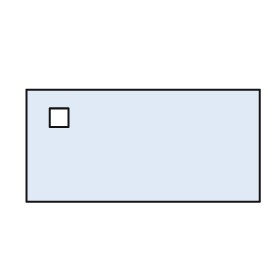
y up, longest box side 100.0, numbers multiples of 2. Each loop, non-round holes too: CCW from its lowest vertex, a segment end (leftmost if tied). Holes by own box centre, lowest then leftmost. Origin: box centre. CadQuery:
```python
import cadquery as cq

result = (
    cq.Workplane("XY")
    .moveTo(-50.0, -24.0)
    .lineTo(50.0, -24.0)
    .lineTo(50.0, 24.0)
    .lineTo(-50.0, 24.0)
    .close()
    .moveTo(-40.0, 8.0)
    .lineTo(-32.0, 8.0)
    .lineTo(-32.0, 16.0)
    .lineTo(-40.0, 16.0)
    .close()
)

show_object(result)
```